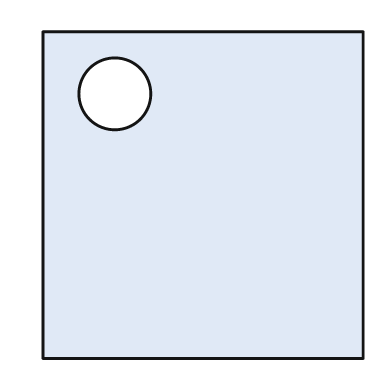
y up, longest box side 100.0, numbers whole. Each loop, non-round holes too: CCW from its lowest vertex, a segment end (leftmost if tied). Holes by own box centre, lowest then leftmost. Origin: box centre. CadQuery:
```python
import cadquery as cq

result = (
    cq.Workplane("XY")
    .moveTo(-49.0, -50.0)
    .lineTo(49.0, -50.0)
    .lineTo(49.0, 50.0)
    .lineTo(-49.0, 50.0)
    .close()
    .moveTo(-27.0, 31.0)
    .circle(11.0)
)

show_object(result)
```